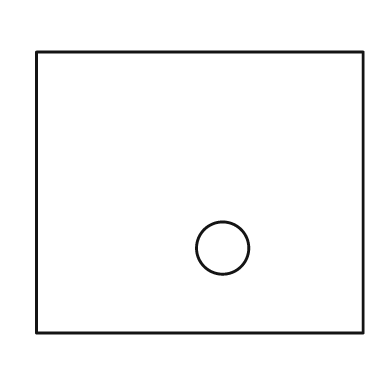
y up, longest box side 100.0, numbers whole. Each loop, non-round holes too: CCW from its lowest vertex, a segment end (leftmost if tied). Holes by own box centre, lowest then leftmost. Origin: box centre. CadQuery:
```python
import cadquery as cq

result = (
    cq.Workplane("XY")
    .moveTo(-50.0, -43.0)
    .lineTo(50.0, -43.0)
    .lineTo(50.0, 43.0)
    .lineTo(-50.0, 43.0)
    .close()
    .moveTo(7.0, -17.0)
    .circle(8.0)
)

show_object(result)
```